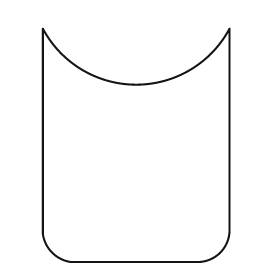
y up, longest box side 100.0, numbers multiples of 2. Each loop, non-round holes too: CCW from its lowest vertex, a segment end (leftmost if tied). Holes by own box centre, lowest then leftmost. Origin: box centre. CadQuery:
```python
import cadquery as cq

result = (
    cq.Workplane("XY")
    .moveTo(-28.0, -50.0)
    .lineTo(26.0, -50.0)
    .threePointArc((36.0, -46.0), (40.0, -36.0))
    .lineTo(40.0, 50.0)
    .threePointArc((0.0, 26.0), (-40.0, 50.0))
    .lineTo(-40.0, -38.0)
    .threePointArc((-36.0, -46.0), (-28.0, -50.0))
    .close()
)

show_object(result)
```